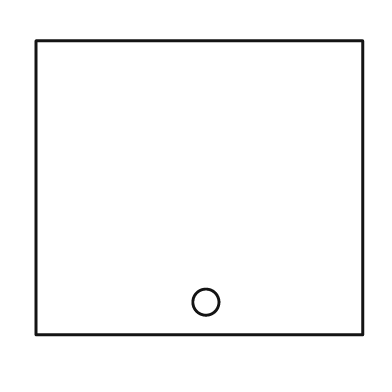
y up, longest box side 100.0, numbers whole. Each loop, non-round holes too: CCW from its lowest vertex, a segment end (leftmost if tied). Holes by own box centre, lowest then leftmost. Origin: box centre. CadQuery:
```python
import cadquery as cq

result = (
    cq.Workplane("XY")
    .moveTo(-50.0, -45.0)
    .lineTo(50.0, -45.0)
    .lineTo(50.0, 45.0)
    .lineTo(-50.0, 45.0)
    .close()
    .moveTo(2.0, -35.0)
    .circle(4.0)
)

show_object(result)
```